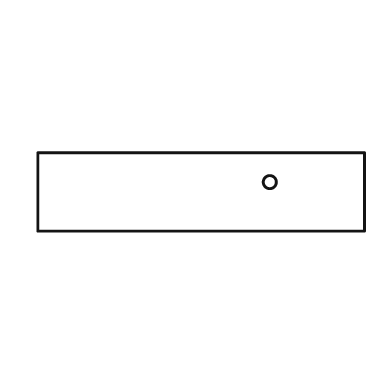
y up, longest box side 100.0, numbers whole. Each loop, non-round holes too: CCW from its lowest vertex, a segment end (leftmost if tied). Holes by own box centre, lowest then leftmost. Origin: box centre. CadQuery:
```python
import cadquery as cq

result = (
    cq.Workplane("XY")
    .moveTo(-50.0, -12.0)
    .lineTo(50.0, -12.0)
    .lineTo(50.0, 12.0)
    .lineTo(-50.0, 12.0)
    .close()
    .moveTo(21.0, 3.0)
    .circle(2.0)
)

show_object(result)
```